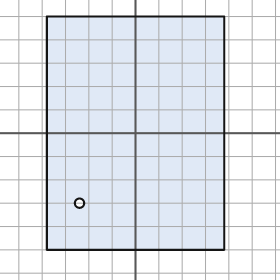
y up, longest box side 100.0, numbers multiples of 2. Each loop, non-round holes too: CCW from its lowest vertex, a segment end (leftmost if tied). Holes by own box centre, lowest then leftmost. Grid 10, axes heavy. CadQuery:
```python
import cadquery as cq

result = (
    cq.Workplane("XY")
    .moveTo(-38.0, -50.0)
    .lineTo(38.0, -50.0)
    .lineTo(38.0, 50.0)
    .lineTo(-38.0, 50.0)
    .close()
    .moveTo(-24.0, -30.0)
    .circle(2.0)
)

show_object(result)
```